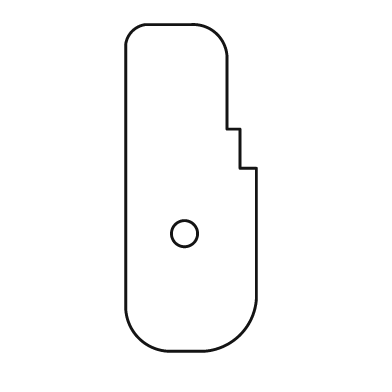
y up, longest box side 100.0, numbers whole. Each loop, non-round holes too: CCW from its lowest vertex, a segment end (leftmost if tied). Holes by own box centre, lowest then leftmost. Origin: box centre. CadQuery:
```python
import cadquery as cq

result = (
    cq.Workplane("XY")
    .moveTo(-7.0, -50.0)
    .lineTo(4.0, -50.0)
    .threePointArc((15.0, -45.0), (20.0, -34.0))
    .lineTo(20.0, 6.0)
    .lineTo(15.0, 6.0)
    .lineTo(15.0, 18.0)
    .lineTo(11.0, 18.0)
    .lineTo(11.0, 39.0)
    .threePointArc((8.0, 47.0), (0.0, 50.0))
    .lineTo(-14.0, 50.0)
    .threePointArc((-18.0, 48.0), (-20.0, 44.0))
    .lineTo(-20.0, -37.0)
    .threePointArc((-16.0, -46.0), (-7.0, -50.0))
    .close()
    .moveTo(-2.0, -14.0)
    .circle(4.0)
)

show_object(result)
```